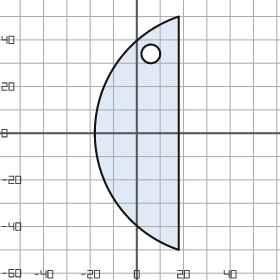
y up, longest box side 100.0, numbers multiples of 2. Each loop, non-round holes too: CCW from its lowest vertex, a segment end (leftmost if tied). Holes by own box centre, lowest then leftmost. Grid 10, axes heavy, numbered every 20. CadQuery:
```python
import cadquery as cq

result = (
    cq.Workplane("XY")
    .moveTo(18.0, -50.0)
    .lineTo(18.0, 50.0)
    .threePointArc((-18.0, 0.0), (18.0, -50.0))
    .close()
    .moveTo(6.0, 34.0)
    .circle(4.0)
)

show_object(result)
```